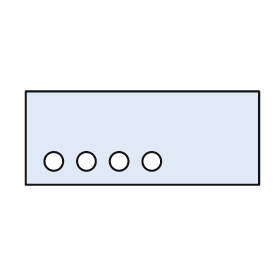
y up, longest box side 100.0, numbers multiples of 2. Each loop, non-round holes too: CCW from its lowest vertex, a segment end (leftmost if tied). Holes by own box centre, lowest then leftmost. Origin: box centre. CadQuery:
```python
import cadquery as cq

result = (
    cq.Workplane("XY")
    .moveTo(-50.0, -20.0)
    .lineTo(50.0, -20.0)
    .lineTo(50.0, 20.0)
    .lineTo(-50.0, 20.0)
    .close()
    .moveTo(-38.0, -10.0)
    .circle(4.0)
    .moveTo(-24.0, -10.0)
    .circle(4.0)
    .moveTo(-10.0, -10.0)
    .circle(4.0)
    .moveTo(4.0, -10.0)
    .circle(4.0)
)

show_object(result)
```